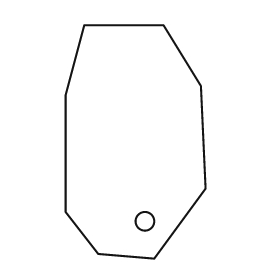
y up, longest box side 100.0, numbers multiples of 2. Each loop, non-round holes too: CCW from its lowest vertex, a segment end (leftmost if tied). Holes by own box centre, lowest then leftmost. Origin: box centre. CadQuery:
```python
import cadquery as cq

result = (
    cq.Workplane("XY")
    .moveTo(8.0, -50.0)
    .lineTo(30.0, -20.0)
    .lineTo(28.0, 24.0)
    .lineTo(12.0, 50.0)
    .lineTo(-22.0, 50.0)
    .lineTo(-30.0, 20.0)
    .lineTo(-30.0, -30.0)
    .lineTo(-16.0, -48.0)
    .close()
    .moveTo(4.0, -34.0)
    .circle(4.0)
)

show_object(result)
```